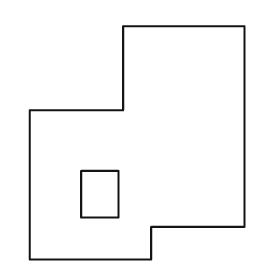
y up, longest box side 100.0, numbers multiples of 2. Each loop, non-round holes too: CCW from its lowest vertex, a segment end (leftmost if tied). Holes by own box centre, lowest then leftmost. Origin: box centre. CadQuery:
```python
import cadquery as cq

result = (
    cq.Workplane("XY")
    .moveTo(-46.0, -50.0)
    .lineTo(6.0, -50.0)
    .lineTo(6.0, -36.0)
    .lineTo(46.0, -36.0)
    .lineTo(46.0, 50.0)
    .lineTo(-6.0, 50.0)
    .lineTo(-6.0, 14.0)
    .lineTo(-46.0, 14.0)
    .close()
    .moveTo(-24.0, -32.0)
    .lineTo(-8.0, -32.0)
    .lineTo(-8.0, -12.0)
    .lineTo(-24.0, -12.0)
    .close()
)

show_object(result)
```